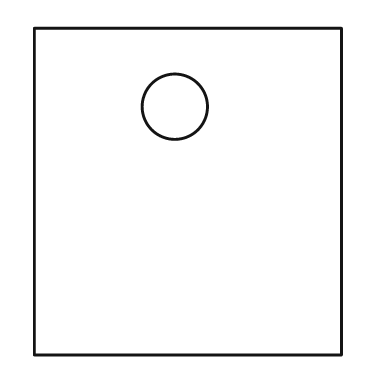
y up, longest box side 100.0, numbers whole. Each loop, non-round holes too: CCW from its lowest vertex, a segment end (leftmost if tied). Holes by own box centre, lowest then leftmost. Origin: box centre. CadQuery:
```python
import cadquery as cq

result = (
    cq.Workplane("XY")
    .moveTo(-47.0, -50.0)
    .lineTo(47.0, -50.0)
    .lineTo(47.0, 50.0)
    .lineTo(-47.0, 50.0)
    .close()
    .moveTo(-4.0, 26.0)
    .circle(10.0)
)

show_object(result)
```